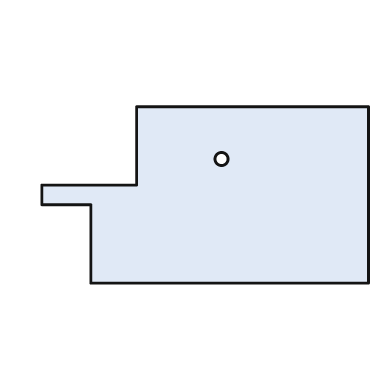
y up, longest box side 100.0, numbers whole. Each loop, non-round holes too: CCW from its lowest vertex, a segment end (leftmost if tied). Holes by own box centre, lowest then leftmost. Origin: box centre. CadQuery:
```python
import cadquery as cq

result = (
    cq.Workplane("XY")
    .moveTo(-35.0, -27.0)
    .lineTo(50.0, -27.0)
    .lineTo(50.0, 27.0)
    .lineTo(-21.0, 27.0)
    .lineTo(-21.0, 3.0)
    .lineTo(-50.0, 3.0)
    .lineTo(-50.0, -3.0)
    .lineTo(-35.0, -3.0)
    .close()
    .moveTo(5.0, 11.0)
    .circle(2.0)
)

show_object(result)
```